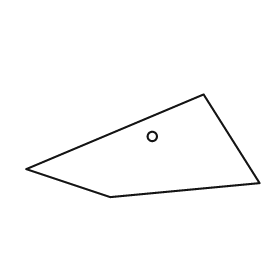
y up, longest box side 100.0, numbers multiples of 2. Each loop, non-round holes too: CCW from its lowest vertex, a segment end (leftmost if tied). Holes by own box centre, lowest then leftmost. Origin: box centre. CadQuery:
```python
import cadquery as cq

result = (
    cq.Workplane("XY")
    .moveTo(-14.0, -22.0)
    .lineTo(50.0, -16.0)
    .lineTo(26.0, 22.0)
    .lineTo(-50.0, -10.0)
    .close()
    .moveTo(4.0, 4.0)
    .circle(2.0)
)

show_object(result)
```